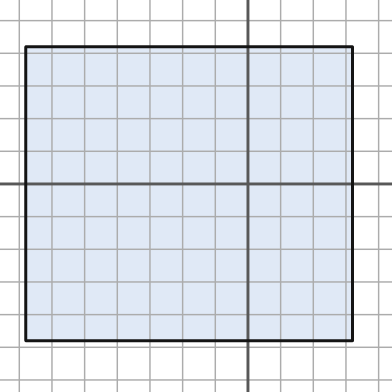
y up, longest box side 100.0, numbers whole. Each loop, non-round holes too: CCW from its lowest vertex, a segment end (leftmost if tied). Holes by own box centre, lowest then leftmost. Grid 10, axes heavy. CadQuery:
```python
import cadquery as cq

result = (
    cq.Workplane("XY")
    .moveTo(-68.0, -48.0)
    .lineTo(32.0, -48.0)
    .lineTo(32.0, 42.0)
    .lineTo(-68.0, 42.0)
    .close()
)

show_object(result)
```